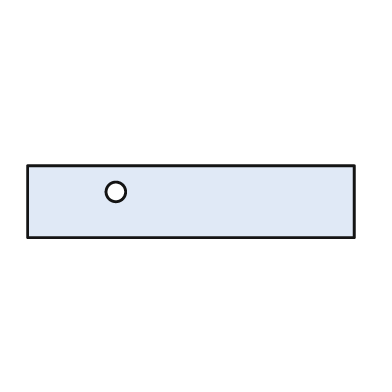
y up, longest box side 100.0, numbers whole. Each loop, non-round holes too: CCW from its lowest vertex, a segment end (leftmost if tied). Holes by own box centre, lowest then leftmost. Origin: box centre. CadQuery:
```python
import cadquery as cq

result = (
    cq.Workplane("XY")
    .moveTo(-50.0, -11.0)
    .lineTo(50.0, -11.0)
    .lineTo(50.0, 11.0)
    .lineTo(-50.0, 11.0)
    .close()
    .moveTo(-23.0, 3.0)
    .circle(3.0)
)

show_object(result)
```